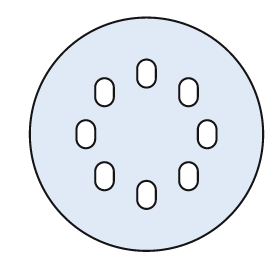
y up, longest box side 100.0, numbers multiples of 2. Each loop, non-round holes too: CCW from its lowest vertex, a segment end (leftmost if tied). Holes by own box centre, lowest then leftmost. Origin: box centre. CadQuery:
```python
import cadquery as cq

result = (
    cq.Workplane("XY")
    .moveTo(0.0, 0.0)
    .circle(50.0)
    .moveTo(-4.0, -28.0)
    .threePointArc((0.0, -32.0), (4.0, -28.0))
    .lineTo(4.0, -24.0)
    .threePointArc((0.0, -20.0), (-4.0, -24.0))
    .close()
    .moveTo(-22.0, -20.0)
    .threePointArc((-18.0, -24.0), (-14.0, -20.0))
    .lineTo(-14.0, -16.0)
    .threePointArc((-18.0, -12.0), (-22.0, -16.0))
    .close()
    .moveTo(14.0, -20.0)
    .threePointArc((18.0, -24.0), (22.0, -20.0))
    .lineTo(22.0, -16.0)
    .threePointArc((18.0, -12.0), (14.0, -16.0))
    .close()
    .moveTo(-30.0, -2.0)
    .threePointArc((-26.0, -6.0), (-22.0, -2.0))
    .lineTo(-22.0, 2.0)
    .threePointArc((-26.0, 6.0), (-30.0, 2.0))
    .close()
    .moveTo(22.0, -2.0)
    .threePointArc((26.0, -6.0), (30.0, -2.0))
    .lineTo(30.0, 2.0)
    .threePointArc((26.0, 6.0), (22.0, 2.0))
    .close()
    .moveTo(-22.0, 16.0)
    .threePointArc((-18.0, 12.0), (-14.0, 16.0))
    .lineTo(-14.0, 20.0)
    .threePointArc((-18.0, 24.0), (-22.0, 20.0))
    .close()
    .moveTo(14.0, 16.0)
    .threePointArc((18.0, 12.0), (22.0, 16.0))
    .lineTo(22.0, 20.0)
    .threePointArc((18.0, 24.0), (14.0, 20.0))
    .close()
    .moveTo(-4.0, 24.0)
    .threePointArc((0.0, 20.0), (4.0, 24.0))
    .lineTo(4.0, 28.0)
    .threePointArc((0.0, 32.0), (-4.0, 28.0))
    .close()
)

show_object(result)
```